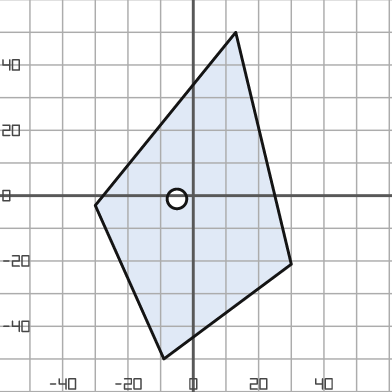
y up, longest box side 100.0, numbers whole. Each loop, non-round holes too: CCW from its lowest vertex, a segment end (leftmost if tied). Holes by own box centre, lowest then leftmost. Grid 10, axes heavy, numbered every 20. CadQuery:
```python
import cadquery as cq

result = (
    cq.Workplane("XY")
    .moveTo(-9.0, -50.0)
    .lineTo(30.0, -21.0)
    .lineTo(13.0, 50.0)
    .lineTo(-30.0, -3.0)
    .close()
    .moveTo(-5.0, -1.0)
    .circle(3.0)
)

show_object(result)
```